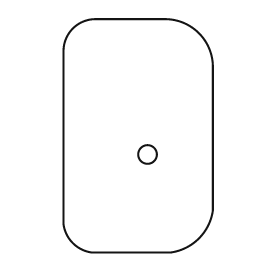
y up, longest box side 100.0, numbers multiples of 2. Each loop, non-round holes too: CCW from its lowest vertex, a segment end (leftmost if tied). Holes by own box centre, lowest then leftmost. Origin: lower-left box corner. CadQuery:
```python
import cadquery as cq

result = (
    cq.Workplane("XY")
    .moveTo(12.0, 0.0)
    .lineTo(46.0, 0.0)
    .threePointArc((58.0, 6.0), (64.0, 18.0))
    .lineTo(64.0, 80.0)
    .threePointArc((58.0, 94.0), (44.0, 100.0))
    .lineTo(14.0, 100.0)
    .threePointArc((4.0, 96.0), (0.0, 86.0))
    .lineTo(0.0, 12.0)
    .threePointArc((4.0, 4.0), (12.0, 0.0))
    .close()
    .moveTo(36.0, 42.0)
    .circle(4.0)
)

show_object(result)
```